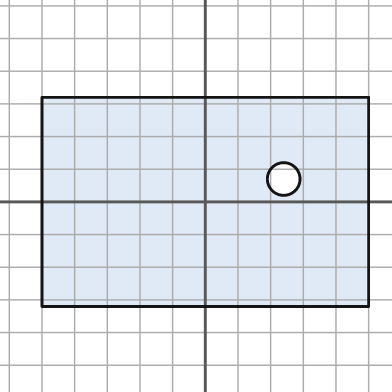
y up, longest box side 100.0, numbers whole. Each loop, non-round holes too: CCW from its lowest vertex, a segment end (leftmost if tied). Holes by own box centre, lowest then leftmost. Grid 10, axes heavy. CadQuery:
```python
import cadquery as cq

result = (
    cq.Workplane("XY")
    .moveTo(-50.0, -32.0)
    .lineTo(50.0, -32.0)
    .lineTo(50.0, 32.0)
    .lineTo(-50.0, 32.0)
    .close()
    .moveTo(24.0, 7.0)
    .circle(5.0)
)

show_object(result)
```